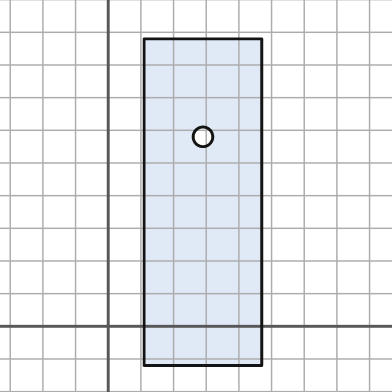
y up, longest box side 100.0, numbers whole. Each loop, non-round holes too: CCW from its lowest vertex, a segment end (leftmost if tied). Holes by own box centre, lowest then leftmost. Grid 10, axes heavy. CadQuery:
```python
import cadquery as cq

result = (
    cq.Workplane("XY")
    .moveTo(11.0, -12.0)
    .lineTo(47.0, -12.0)
    .lineTo(47.0, 88.0)
    .lineTo(11.0, 88.0)
    .close()
    .moveTo(29.0, 58.0)
    .circle(3.0)
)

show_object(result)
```